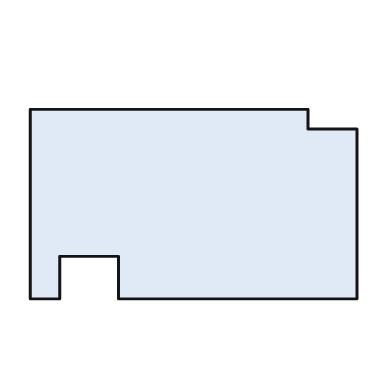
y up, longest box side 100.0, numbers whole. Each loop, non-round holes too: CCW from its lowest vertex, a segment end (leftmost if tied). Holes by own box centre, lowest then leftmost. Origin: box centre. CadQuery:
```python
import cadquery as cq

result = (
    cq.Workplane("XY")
    .moveTo(-50.0, -29.0)
    .lineTo(-41.0, -29.0)
    .lineTo(-41.0, -16.0)
    .lineTo(-23.0, -16.0)
    .lineTo(-23.0, -29.0)
    .lineTo(50.0, -29.0)
    .lineTo(50.0, 23.0)
    .lineTo(35.0, 23.0)
    .lineTo(35.0, 29.0)
    .lineTo(-50.0, 29.0)
    .close()
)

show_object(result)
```